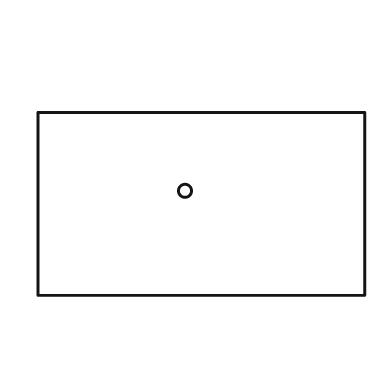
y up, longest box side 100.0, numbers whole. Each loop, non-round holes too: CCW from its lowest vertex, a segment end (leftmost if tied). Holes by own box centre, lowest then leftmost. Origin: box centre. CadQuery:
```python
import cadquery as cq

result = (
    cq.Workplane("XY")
    .moveTo(-50.0, -28.0)
    .lineTo(50.0, -28.0)
    .lineTo(50.0, 28.0)
    .lineTo(-50.0, 28.0)
    .close()
    .moveTo(-5.0, 4.0)
    .circle(2.0)
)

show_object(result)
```